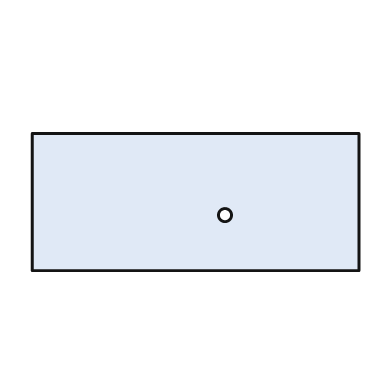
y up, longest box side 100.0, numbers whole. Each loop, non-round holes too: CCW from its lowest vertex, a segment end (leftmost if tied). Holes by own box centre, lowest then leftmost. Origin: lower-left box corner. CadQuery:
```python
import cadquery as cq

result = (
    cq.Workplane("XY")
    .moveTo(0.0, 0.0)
    .lineTo(100.0, 0.0)
    .lineTo(100.0, 42.0)
    .lineTo(0.0, 42.0)
    .close()
    .moveTo(59.0, 17.0)
    .circle(2.0)
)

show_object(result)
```